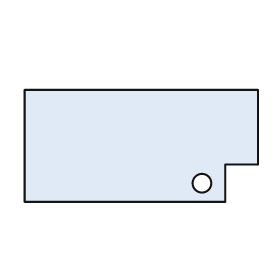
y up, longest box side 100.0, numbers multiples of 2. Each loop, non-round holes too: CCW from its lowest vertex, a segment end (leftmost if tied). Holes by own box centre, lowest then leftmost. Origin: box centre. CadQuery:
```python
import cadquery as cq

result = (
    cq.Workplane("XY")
    .moveTo(-50.0, -24.0)
    .lineTo(36.0, -24.0)
    .lineTo(36.0, -8.0)
    .lineTo(50.0, -8.0)
    .lineTo(50.0, 24.0)
    .lineTo(-50.0, 24.0)
    .close()
    .moveTo(26.0, -16.0)
    .circle(4.0)
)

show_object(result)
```